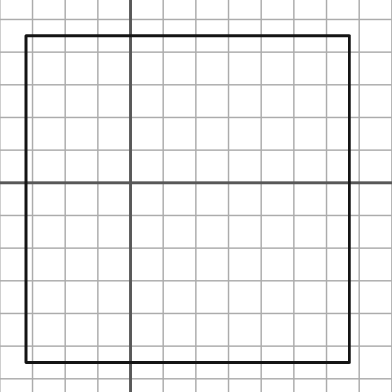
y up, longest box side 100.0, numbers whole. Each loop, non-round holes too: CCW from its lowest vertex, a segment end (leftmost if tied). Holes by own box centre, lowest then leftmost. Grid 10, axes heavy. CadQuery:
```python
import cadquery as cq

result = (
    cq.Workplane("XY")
    .moveTo(-32.0, -55.0)
    .lineTo(67.0, -55.0)
    .lineTo(67.0, 45.0)
    .lineTo(-32.0, 45.0)
    .close()
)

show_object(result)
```